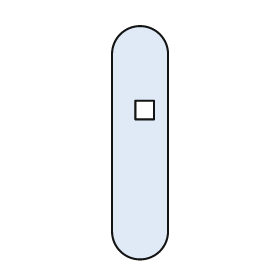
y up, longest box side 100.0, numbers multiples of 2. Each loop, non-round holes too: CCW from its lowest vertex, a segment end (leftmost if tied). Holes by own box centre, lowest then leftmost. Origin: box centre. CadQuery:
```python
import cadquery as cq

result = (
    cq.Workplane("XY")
    .moveTo(-12.0, -38.0)
    .threePointArc((0.0, -50.0), (12.0, -38.0))
    .lineTo(12.0, 38.0)
    .threePointArc((0.0, 50.0), (-12.0, 38.0))
    .close()
    .moveTo(-2.0, 10.0)
    .lineTo(6.0, 10.0)
    .lineTo(6.0, 18.0)
    .lineTo(-2.0, 18.0)
    .close()
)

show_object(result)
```